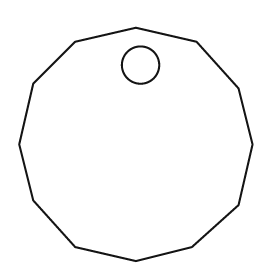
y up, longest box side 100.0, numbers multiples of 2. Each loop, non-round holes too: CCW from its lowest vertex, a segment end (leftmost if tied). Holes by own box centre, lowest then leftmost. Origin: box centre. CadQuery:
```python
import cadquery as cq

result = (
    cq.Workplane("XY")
    .moveTo(0.0, -50.0)
    .lineTo(24.0, -44.0)
    .lineTo(44.0, -26.0)
    .lineTo(50.0, 0.0)
    .lineTo(44.0, 24.0)
    .lineTo(26.0, 44.0)
    .lineTo(0.0, 50.0)
    .lineTo(-26.0, 44.0)
    .lineTo(-44.0, 26.0)
    .lineTo(-50.0, 0.0)
    .lineTo(-44.0, -24.0)
    .lineTo(-26.0, -44.0)
    .close()
    .moveTo(2.0, 34.0)
    .circle(8.0)
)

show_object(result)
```